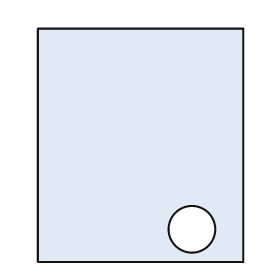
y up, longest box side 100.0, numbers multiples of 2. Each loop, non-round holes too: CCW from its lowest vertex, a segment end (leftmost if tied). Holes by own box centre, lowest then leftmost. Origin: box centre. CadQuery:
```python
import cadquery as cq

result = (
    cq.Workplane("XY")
    .moveTo(-44.0, -50.0)
    .lineTo(44.0, -50.0)
    .lineTo(44.0, 50.0)
    .lineTo(-44.0, 50.0)
    .close()
    .moveTo(22.0, -36.0)
    .circle(10.0)
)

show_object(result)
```